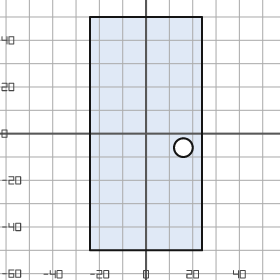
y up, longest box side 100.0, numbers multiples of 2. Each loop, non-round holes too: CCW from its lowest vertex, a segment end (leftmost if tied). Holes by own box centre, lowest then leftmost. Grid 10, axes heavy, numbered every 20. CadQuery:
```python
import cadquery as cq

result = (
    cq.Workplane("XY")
    .moveTo(-24.0, -50.0)
    .lineTo(24.0, -50.0)
    .lineTo(24.0, 50.0)
    .lineTo(-24.0, 50.0)
    .close()
    .moveTo(16.0, -6.0)
    .circle(4.0)
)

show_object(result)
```